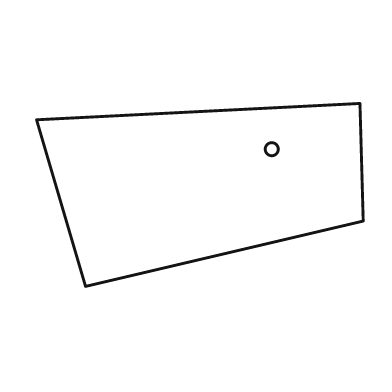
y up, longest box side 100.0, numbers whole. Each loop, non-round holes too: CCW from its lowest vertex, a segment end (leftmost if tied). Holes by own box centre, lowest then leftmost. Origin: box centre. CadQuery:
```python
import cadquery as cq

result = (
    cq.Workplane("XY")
    .moveTo(-35.0, -28.0)
    .lineTo(50.0, -8.0)
    .lineTo(49.0, 28.0)
    .lineTo(-50.0, 23.0)
    .close()
    .moveTo(22.0, 14.0)
    .circle(2.0)
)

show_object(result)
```